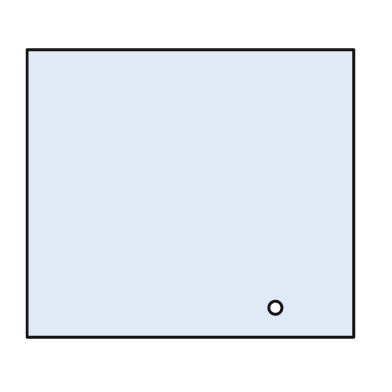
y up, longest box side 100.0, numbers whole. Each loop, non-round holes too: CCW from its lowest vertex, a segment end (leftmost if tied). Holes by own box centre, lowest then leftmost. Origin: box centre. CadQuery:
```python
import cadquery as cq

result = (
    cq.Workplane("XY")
    .moveTo(-50.0, -44.0)
    .lineTo(50.0, -44.0)
    .lineTo(50.0, 44.0)
    .lineTo(-50.0, 44.0)
    .close()
    .moveTo(26.0, -35.0)
    .circle(2.0)
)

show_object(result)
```